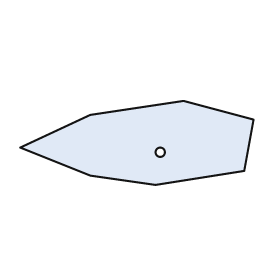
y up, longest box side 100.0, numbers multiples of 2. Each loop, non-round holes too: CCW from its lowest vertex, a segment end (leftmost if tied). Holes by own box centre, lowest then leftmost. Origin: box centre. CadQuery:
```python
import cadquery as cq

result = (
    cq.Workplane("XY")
    .moveTo(8.0, -18.0)
    .lineTo(46.0, -12.0)
    .lineTo(50.0, 10.0)
    .lineTo(20.0, 18.0)
    .lineTo(-20.0, 12.0)
    .lineTo(-50.0, -2.0)
    .lineTo(-20.0, -14.0)
    .close()
    .moveTo(10.0, -4.0)
    .circle(2.0)
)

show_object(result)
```